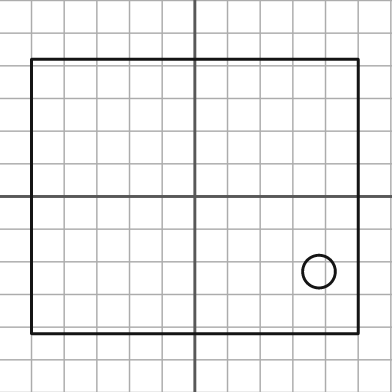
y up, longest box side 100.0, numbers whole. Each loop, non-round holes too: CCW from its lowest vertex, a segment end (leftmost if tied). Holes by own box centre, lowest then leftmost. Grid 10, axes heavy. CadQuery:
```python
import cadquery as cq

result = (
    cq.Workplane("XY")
    .moveTo(-50.0, -42.0)
    .lineTo(50.0, -42.0)
    .lineTo(50.0, 42.0)
    .lineTo(-50.0, 42.0)
    .close()
    .moveTo(38.0, -23.0)
    .circle(5.0)
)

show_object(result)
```